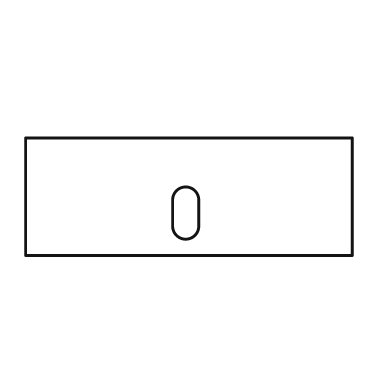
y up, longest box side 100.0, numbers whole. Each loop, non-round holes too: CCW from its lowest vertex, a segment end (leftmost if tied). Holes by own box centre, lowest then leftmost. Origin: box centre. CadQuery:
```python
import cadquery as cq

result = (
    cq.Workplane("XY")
    .moveTo(-50.0, -18.0)
    .lineTo(50.0, -18.0)
    .lineTo(50.0, 18.0)
    .lineTo(-50.0, 18.0)
    .close()
    .moveTo(-5.0, -9.0)
    .threePointArc((-1.0, -13.0), (3.0, -9.0))
    .lineTo(3.0, -1.0)
    .threePointArc((-1.0, 3.0), (-5.0, -1.0))
    .close()
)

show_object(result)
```